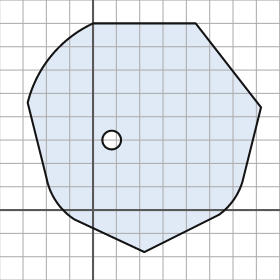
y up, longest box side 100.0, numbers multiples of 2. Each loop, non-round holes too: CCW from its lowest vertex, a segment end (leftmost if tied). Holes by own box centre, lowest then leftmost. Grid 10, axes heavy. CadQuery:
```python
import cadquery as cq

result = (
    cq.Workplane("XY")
    .moveTo(22.0, -18.0)
    .lineTo(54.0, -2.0)
    .threePointArc((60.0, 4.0), (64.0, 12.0))
    .lineTo(72.0, 44.0)
    .lineTo(44.0, 80.0)
    .lineTo(0.0, 80.0)
    .threePointArc((-18.0, 66.0), (-28.0, 46.0))
    .lineTo(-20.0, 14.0)
    .threePointArc((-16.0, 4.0), (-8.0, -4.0))
    .close()
    .moveTo(8.0, 30.0)
    .circle(4.0)
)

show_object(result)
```